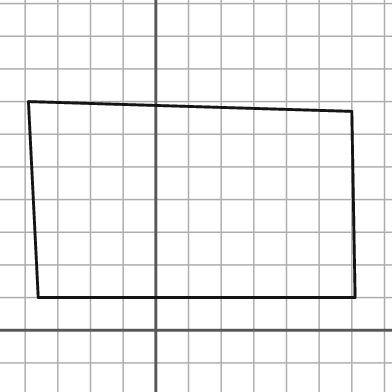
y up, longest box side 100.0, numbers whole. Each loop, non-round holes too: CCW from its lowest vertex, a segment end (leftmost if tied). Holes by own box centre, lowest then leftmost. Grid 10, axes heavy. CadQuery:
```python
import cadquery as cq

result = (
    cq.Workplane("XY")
    .moveTo(-36.0, 10.0)
    .lineTo(61.0, 10.0)
    .lineTo(60.0, 67.0)
    .lineTo(-39.0, 70.0)
    .close()
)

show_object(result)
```